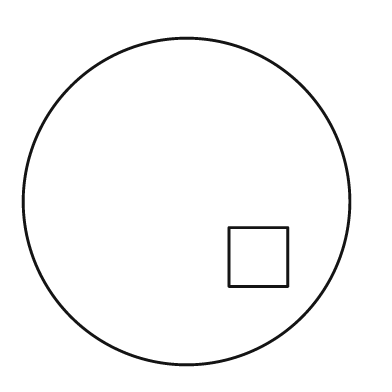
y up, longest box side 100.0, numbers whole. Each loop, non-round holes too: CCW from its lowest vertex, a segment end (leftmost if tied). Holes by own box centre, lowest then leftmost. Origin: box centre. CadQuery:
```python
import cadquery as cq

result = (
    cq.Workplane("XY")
    .moveTo(0.0, 0.0)
    .circle(50.0)
    .moveTo(13.0, -26.0)
    .lineTo(31.0, -26.0)
    .lineTo(31.0, -8.0)
    .lineTo(13.0, -8.0)
    .close()
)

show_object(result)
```